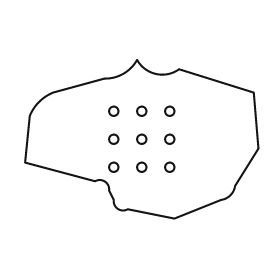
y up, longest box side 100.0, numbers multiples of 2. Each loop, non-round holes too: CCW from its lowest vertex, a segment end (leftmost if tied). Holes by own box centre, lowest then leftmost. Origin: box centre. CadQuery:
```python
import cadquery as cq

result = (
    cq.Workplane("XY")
    .moveTo(14.0, -34.0)
    .lineTo(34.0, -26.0)
    .threePointArc((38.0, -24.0), (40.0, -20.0))
    .lineTo(50.0, -4.0)
    .lineTo(48.0, 20.0)
    .lineTo(16.0, 30.0)
    .threePointArc((6.0, 28.0), (-2.0, 34.0))
    .threePointArc((-8.0, 28.0), (-16.0, 26.0))
    .lineTo(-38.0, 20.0)
    .threePointArc((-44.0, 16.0), (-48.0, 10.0))
    .lineTo(-50.0, -10.0)
    .lineTo(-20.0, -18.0)
    .threePointArc((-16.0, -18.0), (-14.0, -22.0))
    .lineTo(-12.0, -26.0)
    .threePointArc((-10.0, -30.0), (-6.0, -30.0))
    .close()
    .moveTo(-12.0, -12.0)
    .circle(2.0)
    .moveTo(0.0, -12.0)
    .circle(2.0)
    .moveTo(12.0, -12.0)
    .circle(2.0)
    .moveTo(-12.0, 0.0)
    .circle(2.0)
    .moveTo(0.0, 0.0)
    .circle(2.0)
    .moveTo(12.0, 0.0)
    .circle(2.0)
    .moveTo(-12.0, 12.0)
    .circle(2.0)
    .moveTo(0.0, 12.0)
    .circle(2.0)
    .moveTo(12.0, 12.0)
    .circle(2.0)
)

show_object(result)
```